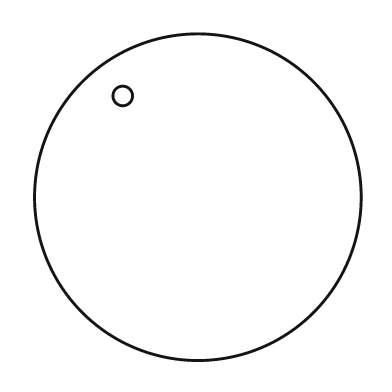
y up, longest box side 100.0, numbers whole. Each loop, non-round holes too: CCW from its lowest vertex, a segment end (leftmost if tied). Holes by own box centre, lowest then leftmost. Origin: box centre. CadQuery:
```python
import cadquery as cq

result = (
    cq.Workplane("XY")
    .moveTo(0.0, 0.0)
    .circle(50.0)
    .moveTo(-23.0, 31.0)
    .circle(3.0)
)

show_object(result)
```